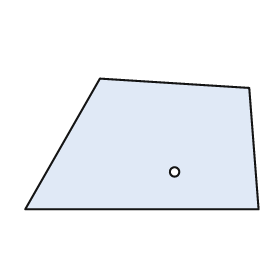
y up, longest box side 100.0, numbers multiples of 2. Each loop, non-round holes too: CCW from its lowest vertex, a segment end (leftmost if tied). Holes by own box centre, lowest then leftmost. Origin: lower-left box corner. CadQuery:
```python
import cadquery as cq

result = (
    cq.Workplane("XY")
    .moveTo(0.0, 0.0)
    .lineTo(100.0, 0.0)
    .lineTo(96.0, 52.0)
    .lineTo(32.0, 56.0)
    .close()
    .moveTo(64.0, 16.0)
    .circle(2.0)
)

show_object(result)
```